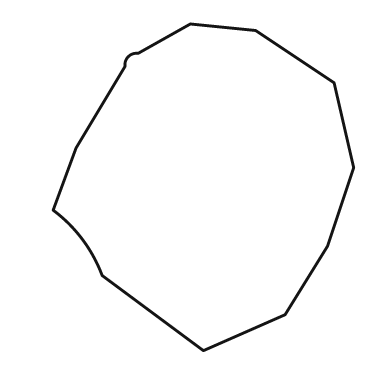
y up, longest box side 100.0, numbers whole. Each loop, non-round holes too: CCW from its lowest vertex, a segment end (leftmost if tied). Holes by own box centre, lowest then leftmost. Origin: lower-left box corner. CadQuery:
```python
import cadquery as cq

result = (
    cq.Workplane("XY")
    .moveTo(46.0, 0.0)
    .lineTo(71.0, 11.0)
    .lineTo(84.0, 32.0)
    .lineTo(92.0, 56.0)
    .lineTo(86.0, 82.0)
    .lineTo(62.0, 98.0)
    .lineTo(42.0, 100.0)
    .lineTo(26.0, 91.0)
    .threePointArc((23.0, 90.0), (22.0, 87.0))
    .lineTo(7.0, 62.0)
    .lineTo(0.0, 43.0)
    .threePointArc((9.0, 34.0), (15.0, 23.0))
    .close()
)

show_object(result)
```